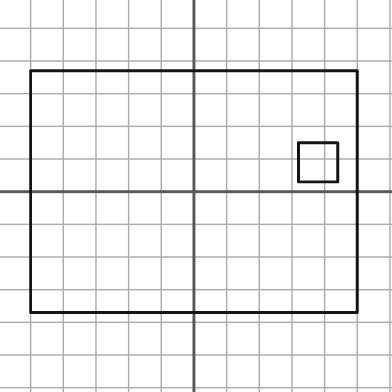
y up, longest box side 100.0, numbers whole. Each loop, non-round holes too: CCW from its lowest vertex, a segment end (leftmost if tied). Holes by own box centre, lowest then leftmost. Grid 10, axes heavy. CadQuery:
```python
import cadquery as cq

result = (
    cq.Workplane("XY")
    .moveTo(-50.0, -37.0)
    .lineTo(50.0, -37.0)
    .lineTo(50.0, 37.0)
    .lineTo(-50.0, 37.0)
    .close()
    .moveTo(32.0, 3.0)
    .lineTo(44.0, 3.0)
    .lineTo(44.0, 15.0)
    .lineTo(32.0, 15.0)
    .close()
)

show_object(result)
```